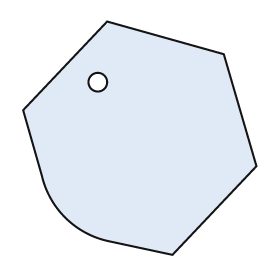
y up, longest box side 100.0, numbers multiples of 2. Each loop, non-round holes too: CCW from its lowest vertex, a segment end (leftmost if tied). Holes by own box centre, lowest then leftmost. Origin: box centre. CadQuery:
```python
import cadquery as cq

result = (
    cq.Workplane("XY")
    .moveTo(14.0, -50.0)
    .lineTo(50.0, -12.0)
    .lineTo(36.0, 36.0)
    .lineTo(-14.0, 50.0)
    .lineTo(-50.0, 12.0)
    .lineTo(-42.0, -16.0)
    .threePointArc((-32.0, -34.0), (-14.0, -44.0))
    .close()
    .moveTo(-18.0, 24.0)
    .circle(4.0)
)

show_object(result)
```